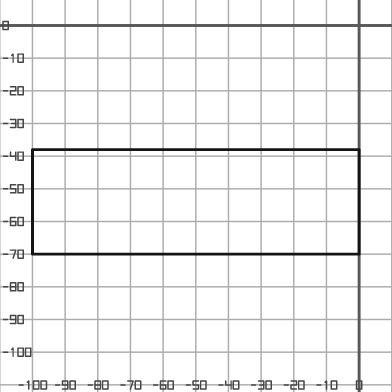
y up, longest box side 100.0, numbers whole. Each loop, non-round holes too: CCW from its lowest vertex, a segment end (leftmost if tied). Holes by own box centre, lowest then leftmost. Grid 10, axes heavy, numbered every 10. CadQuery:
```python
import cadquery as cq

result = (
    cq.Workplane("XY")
    .moveTo(-100.0, -70.0)
    .lineTo(0.0, -70.0)
    .lineTo(0.0, -38.0)
    .lineTo(-100.0, -38.0)
    .close()
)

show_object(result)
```